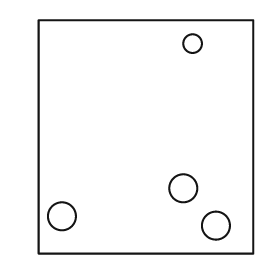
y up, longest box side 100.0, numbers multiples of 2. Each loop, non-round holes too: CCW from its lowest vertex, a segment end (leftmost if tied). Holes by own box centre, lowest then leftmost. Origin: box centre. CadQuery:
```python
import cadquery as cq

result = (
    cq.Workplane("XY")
    .moveTo(-46.0, -50.0)
    .lineTo(46.0, -50.0)
    .lineTo(46.0, 50.0)
    .lineTo(-46.0, 50.0)
    .close()
    .moveTo(30.0, -38.0)
    .circle(6.0)
    .moveTo(-36.0, -34.0)
    .circle(6.0)
    .moveTo(16.0, -22.0)
    .circle(6.0)
    .moveTo(20.0, 40.0)
    .circle(4.0)
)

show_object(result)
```